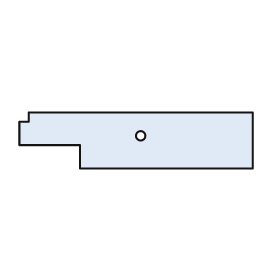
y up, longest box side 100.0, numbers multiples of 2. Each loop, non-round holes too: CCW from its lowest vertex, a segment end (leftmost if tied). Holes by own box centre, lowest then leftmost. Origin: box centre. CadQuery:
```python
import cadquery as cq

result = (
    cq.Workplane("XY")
    .moveTo(-24.0, -12.0)
    .lineTo(50.0, -12.0)
    .lineTo(50.0, 12.0)
    .lineTo(-46.0, 12.0)
    .lineTo(-46.0, 8.0)
    .lineTo(-50.0, 8.0)
    .lineTo(-50.0, -2.0)
    .lineTo(-24.0, -2.0)
    .close()
    .moveTo(2.0, 2.0)
    .circle(2.0)
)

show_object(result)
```